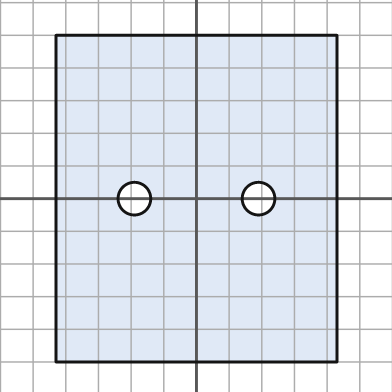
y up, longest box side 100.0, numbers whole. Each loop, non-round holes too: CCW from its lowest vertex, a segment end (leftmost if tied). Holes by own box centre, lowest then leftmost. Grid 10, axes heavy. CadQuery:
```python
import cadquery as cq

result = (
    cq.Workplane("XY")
    .moveTo(-43.0, -50.0)
    .lineTo(43.0, -50.0)
    .lineTo(43.0, 50.0)
    .lineTo(-43.0, 50.0)
    .close()
    .moveTo(-19.0, 0.0)
    .circle(5.0)
    .moveTo(19.0, 0.0)
    .circle(5.0)
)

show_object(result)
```